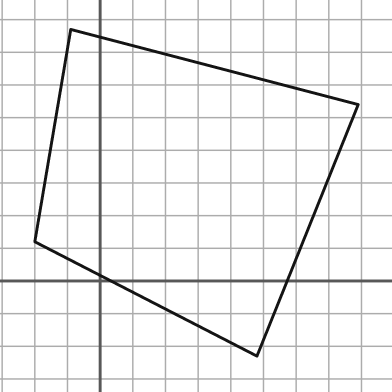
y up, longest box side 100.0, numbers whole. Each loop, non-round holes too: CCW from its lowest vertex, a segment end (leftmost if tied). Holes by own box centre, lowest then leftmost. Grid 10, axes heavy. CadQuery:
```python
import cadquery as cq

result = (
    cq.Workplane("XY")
    .moveTo(48.0, -23.0)
    .lineTo(79.0, 54.0)
    .lineTo(-9.0, 77.0)
    .lineTo(-20.0, 12.0)
    .close()
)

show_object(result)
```